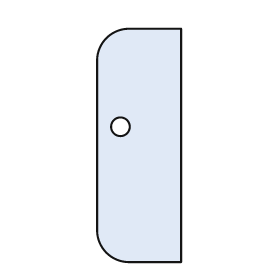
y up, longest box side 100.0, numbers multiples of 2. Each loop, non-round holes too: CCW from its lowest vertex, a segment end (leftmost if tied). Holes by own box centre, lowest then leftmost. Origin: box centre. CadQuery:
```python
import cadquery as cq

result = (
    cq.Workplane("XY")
    .moveTo(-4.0, -50.0)
    .lineTo(18.0, -50.0)
    .lineTo(18.0, 50.0)
    .lineTo(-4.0, 50.0)
    .threePointArc((-14.0, 46.0), (-18.0, 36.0))
    .lineTo(-18.0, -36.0)
    .threePointArc((-14.0, -46.0), (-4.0, -50.0))
    .close()
    .moveTo(-8.0, 8.0)
    .circle(4.0)
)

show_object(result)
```